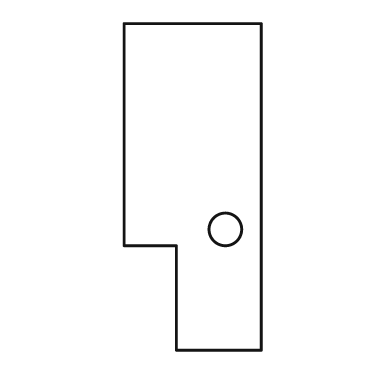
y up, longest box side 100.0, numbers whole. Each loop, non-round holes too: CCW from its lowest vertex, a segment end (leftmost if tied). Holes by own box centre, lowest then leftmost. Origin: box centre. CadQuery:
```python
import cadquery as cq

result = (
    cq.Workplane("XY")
    .moveTo(-5.0, -50.0)
    .lineTo(21.0, -50.0)
    .lineTo(21.0, 50.0)
    .lineTo(-21.0, 50.0)
    .lineTo(-21.0, -18.0)
    .lineTo(-5.0, -18.0)
    .close()
    .moveTo(10.0, -13.0)
    .circle(5.0)
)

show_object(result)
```